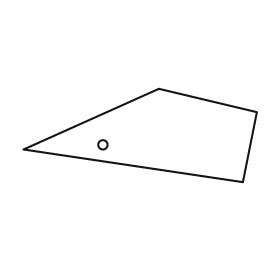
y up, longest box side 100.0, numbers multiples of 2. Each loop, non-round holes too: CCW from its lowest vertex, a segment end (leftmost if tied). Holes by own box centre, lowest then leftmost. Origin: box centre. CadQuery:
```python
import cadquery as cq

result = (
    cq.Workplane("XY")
    .moveTo(44.0, -20.0)
    .lineTo(50.0, 10.0)
    .lineTo(8.0, 20.0)
    .lineTo(-50.0, -6.0)
    .close()
    .moveTo(-16.0, -4.0)
    .circle(2.0)
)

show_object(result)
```